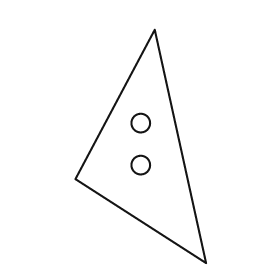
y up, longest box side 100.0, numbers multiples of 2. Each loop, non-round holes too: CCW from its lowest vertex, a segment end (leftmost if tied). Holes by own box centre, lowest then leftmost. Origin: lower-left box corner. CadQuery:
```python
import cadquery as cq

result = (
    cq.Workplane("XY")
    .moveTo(56.0, 0.0)
    .lineTo(34.0, 100.0)
    .lineTo(0.0, 36.0)
    .close()
    .moveTo(28.0, 42.0)
    .circle(4.0)
    .moveTo(28.0, 60.0)
    .circle(4.0)
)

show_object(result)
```